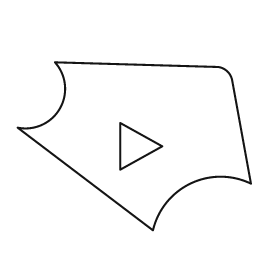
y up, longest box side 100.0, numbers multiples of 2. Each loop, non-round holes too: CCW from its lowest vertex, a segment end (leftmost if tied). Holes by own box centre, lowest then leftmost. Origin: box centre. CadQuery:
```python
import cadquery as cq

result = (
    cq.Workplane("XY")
    .moveTo(8.0, -36.0)
    .threePointArc((24.0, -16.0), (50.0, -16.0))
    .lineTo(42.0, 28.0)
    .threePointArc((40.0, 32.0), (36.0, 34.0))
    .lineTo(-34.0, 36.0)
    .threePointArc((-32.0, 16.0), (-50.0, 8.0))
    .close()
    .moveTo(-6.0, -10.0)
    .lineTo(12.0, 0.0)
    .lineTo(-6.0, 10.0)
    .close()
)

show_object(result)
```